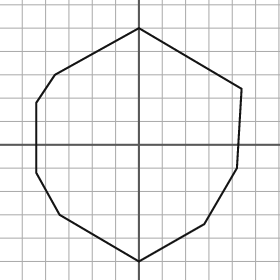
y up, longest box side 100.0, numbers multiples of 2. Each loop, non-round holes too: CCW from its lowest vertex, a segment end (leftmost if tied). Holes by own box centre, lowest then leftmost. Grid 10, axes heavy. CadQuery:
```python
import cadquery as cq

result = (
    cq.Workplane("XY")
    .moveTo(0.0, -50.0)
    .lineTo(28.0, -34.0)
    .lineTo(42.0, -10.0)
    .lineTo(44.0, 24.0)
    .lineTo(0.0, 50.0)
    .lineTo(-36.0, 30.0)
    .lineTo(-44.0, 18.0)
    .lineTo(-44.0, -12.0)
    .lineTo(-34.0, -30.0)
    .close()
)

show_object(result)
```